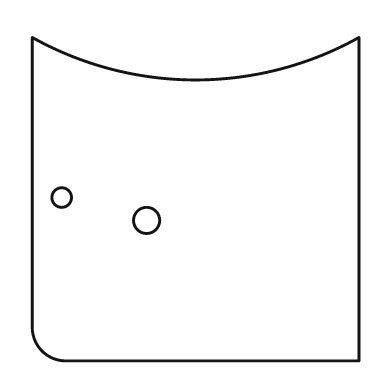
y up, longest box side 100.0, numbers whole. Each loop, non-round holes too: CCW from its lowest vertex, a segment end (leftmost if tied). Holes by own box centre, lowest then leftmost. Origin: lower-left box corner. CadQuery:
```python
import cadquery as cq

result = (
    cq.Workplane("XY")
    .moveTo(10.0, 0.0)
    .lineTo(100.0, 0.0)
    .lineTo(100.0, 99.0)
    .threePointArc((50.0, 86.0), (0.0, 99.0))
    .lineTo(0.0, 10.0)
    .threePointArc((3.0, 3.0), (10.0, 0.0))
    .close()
    .moveTo(35.0, 43.0)
    .circle(4.0)
    .moveTo(9.0, 50.0)
    .circle(3.0)
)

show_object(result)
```